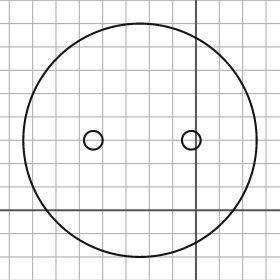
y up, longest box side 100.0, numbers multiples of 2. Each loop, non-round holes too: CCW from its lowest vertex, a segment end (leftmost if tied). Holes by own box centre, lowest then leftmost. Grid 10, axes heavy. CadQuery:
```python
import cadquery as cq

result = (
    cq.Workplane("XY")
    .moveTo(-24.0, 30.0)
    .circle(50.0)
    .moveTo(-44.0, 30.0)
    .circle(4.0)
    .moveTo(-2.0, 30.0)
    .circle(4.0)
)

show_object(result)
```